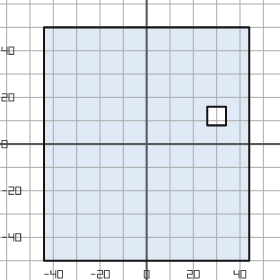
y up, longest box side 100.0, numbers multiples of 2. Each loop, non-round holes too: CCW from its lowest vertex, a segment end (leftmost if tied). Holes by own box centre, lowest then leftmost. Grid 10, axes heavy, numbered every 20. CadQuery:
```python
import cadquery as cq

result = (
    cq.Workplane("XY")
    .moveTo(-44.0, -50.0)
    .lineTo(44.0, -50.0)
    .lineTo(44.0, 50.0)
    .lineTo(-44.0, 50.0)
    .close()
    .moveTo(26.0, 8.0)
    .lineTo(34.0, 8.0)
    .lineTo(34.0, 16.0)
    .lineTo(26.0, 16.0)
    .close()
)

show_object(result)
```